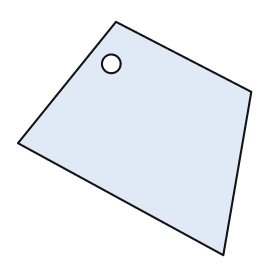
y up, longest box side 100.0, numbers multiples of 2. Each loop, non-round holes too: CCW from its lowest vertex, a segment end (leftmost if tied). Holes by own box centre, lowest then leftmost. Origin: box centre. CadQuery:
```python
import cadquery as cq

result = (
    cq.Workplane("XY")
    .moveTo(38.0, -50.0)
    .lineTo(50.0, 20.0)
    .lineTo(-8.0, 50.0)
    .lineTo(-50.0, -2.0)
    .close()
    .moveTo(-10.0, 32.0)
    .circle(4.0)
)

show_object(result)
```